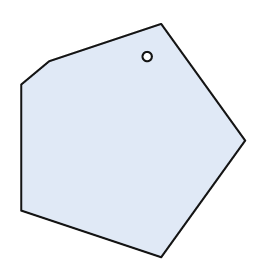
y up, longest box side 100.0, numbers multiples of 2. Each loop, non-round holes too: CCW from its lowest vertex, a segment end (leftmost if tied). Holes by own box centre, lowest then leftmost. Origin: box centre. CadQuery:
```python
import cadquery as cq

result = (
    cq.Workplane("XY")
    .moveTo(12.0, -50.0)
    .lineTo(48.0, 0.0)
    .lineTo(12.0, 50.0)
    .lineTo(-36.0, 34.0)
    .lineTo(-48.0, 24.0)
    .lineTo(-48.0, -30.0)
    .close()
    .moveTo(6.0, 36.0)
    .circle(2.0)
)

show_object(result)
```